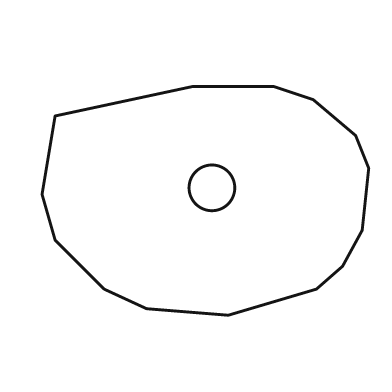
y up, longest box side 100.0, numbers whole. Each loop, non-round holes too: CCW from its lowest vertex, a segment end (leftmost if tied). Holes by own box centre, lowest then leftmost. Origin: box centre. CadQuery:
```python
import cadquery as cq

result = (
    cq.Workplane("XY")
    .moveTo(7.0, -35.0)
    .lineTo(34.0, -27.0)
    .lineTo(42.0, -20.0)
    .lineTo(48.0, -9.0)
    .lineTo(50.0, 10.0)
    .lineTo(46.0, 20.0)
    .lineTo(33.0, 31.0)
    .lineTo(21.0, 35.0)
    .lineTo(-4.0, 35.0)
    .lineTo(-46.0, 26.0)
    .lineTo(-50.0, 2.0)
    .lineTo(-46.0, -12.0)
    .lineTo(-31.0, -27.0)
    .lineTo(-18.0, -33.0)
    .close()
    .moveTo(2.0, 4.0)
    .circle(7.0)
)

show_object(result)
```